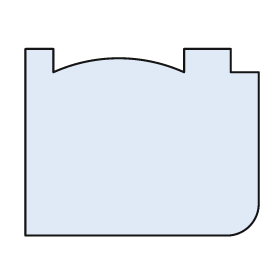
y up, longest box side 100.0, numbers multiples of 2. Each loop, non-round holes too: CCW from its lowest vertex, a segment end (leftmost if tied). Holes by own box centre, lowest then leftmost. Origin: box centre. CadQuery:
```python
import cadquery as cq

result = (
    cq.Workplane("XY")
    .moveTo(-50.0, -40.0)
    .lineTo(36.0, -40.0)
    .threePointArc((46.0, -36.0), (50.0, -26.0))
    .lineTo(50.0, 30.0)
    .lineTo(38.0, 30.0)
    .lineTo(38.0, 40.0)
    .lineTo(18.0, 40.0)
    .lineTo(18.0, 30.0)
    .threePointArc((-10.0, 36.0), (-38.0, 30.0))
    .lineTo(-38.0, 40.0)
    .lineTo(-50.0, 40.0)
    .close()
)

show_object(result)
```